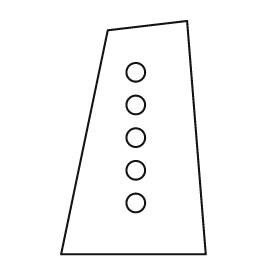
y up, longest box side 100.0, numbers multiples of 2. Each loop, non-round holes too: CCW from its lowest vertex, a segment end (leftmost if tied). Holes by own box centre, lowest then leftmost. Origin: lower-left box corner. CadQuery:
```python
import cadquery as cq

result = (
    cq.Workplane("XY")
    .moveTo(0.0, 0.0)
    .lineTo(62.0, 0.0)
    .lineTo(54.0, 100.0)
    .lineTo(20.0, 96.0)
    .close()
    .moveTo(32.0, 22.0)
    .circle(4.0)
    .moveTo(32.0, 36.0)
    .circle(4.0)
    .moveTo(32.0, 50.0)
    .circle(4.0)
    .moveTo(32.0, 64.0)
    .circle(4.0)
    .moveTo(32.0, 78.0)
    .circle(4.0)
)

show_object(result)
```